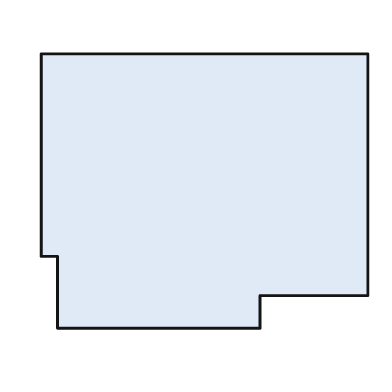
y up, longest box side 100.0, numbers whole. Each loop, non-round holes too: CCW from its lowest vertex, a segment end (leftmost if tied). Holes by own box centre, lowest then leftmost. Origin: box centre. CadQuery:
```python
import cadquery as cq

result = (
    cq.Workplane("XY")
    .moveTo(-45.0, -42.0)
    .lineTo(17.0, -42.0)
    .lineTo(17.0, -32.0)
    .lineTo(50.0, -32.0)
    .lineTo(50.0, 42.0)
    .lineTo(-50.0, 42.0)
    .lineTo(-50.0, -20.0)
    .lineTo(-45.0, -20.0)
    .close()
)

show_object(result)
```